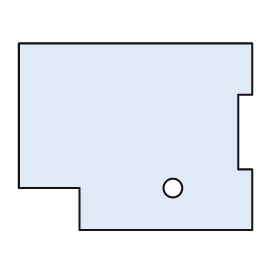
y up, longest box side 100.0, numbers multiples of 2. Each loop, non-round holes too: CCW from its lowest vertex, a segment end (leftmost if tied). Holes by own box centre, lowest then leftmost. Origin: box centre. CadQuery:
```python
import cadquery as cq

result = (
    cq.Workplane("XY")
    .moveTo(-24.0, -40.0)
    .lineTo(50.0, -40.0)
    .lineTo(50.0, -14.0)
    .lineTo(44.0, -14.0)
    .lineTo(44.0, 18.0)
    .lineTo(50.0, 18.0)
    .lineTo(50.0, 40.0)
    .lineTo(-50.0, 40.0)
    .lineTo(-50.0, -22.0)
    .lineTo(-24.0, -22.0)
    .close()
    .moveTo(16.0, -22.0)
    .circle(4.0)
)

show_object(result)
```